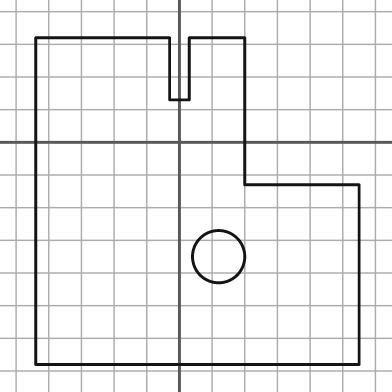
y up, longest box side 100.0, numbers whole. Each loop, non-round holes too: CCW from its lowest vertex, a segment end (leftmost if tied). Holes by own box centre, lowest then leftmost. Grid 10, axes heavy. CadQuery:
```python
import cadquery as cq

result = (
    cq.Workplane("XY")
    .moveTo(-44.0, -68.0)
    .lineTo(55.0, -68.0)
    .lineTo(55.0, -13.0)
    .lineTo(20.0, -13.0)
    .lineTo(20.0, 32.0)
    .lineTo(3.0, 32.0)
    .lineTo(3.0, 13.0)
    .lineTo(-3.0, 13.0)
    .lineTo(-3.0, 32.0)
    .lineTo(-44.0, 32.0)
    .close()
    .moveTo(12.0, -35.0)
    .circle(8.0)
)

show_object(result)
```